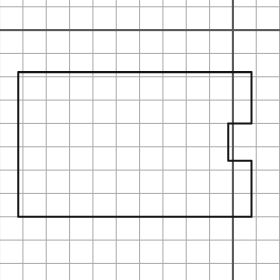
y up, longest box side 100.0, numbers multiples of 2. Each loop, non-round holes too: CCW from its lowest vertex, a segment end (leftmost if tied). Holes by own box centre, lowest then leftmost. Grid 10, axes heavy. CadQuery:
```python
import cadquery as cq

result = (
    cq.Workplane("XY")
    .moveTo(-92.0, -80.0)
    .lineTo(8.0, -80.0)
    .lineTo(8.0, -56.0)
    .lineTo(-2.0, -56.0)
    .lineTo(-2.0, -40.0)
    .lineTo(8.0, -40.0)
    .lineTo(8.0, -18.0)
    .lineTo(-92.0, -18.0)
    .close()
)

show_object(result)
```